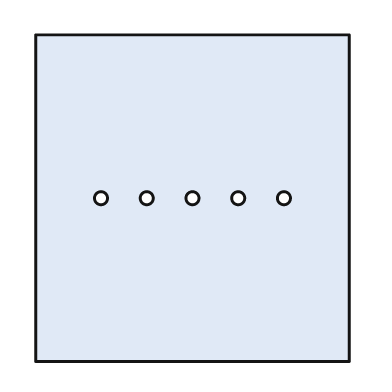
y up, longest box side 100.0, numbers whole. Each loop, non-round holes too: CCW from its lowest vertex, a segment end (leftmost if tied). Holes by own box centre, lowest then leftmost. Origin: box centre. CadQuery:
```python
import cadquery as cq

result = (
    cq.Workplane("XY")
    .moveTo(-48.0, -50.0)
    .lineTo(48.0, -50.0)
    .lineTo(48.0, 50.0)
    .lineTo(-48.0, 50.0)
    .close()
    .moveTo(-28.0, 0.0)
    .circle(2.0)
    .moveTo(-14.0, 0.0)
    .circle(2.0)
    .moveTo(0.0, 0.0)
    .circle(2.0)
    .moveTo(14.0, 0.0)
    .circle(2.0)
    .moveTo(28.0, 0.0)
    .circle(2.0)
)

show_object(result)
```